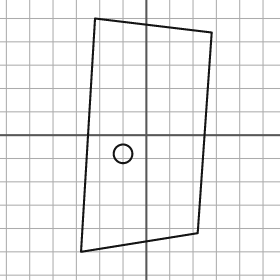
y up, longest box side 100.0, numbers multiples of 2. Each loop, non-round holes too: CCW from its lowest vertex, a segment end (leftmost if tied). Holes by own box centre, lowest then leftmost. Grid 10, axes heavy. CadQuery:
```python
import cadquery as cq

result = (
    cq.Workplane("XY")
    .moveTo(-28.0, -50.0)
    .lineTo(22.0, -42.0)
    .lineTo(28.0, 44.0)
    .lineTo(-22.0, 50.0)
    .close()
    .moveTo(-10.0, -8.0)
    .circle(4.0)
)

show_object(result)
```